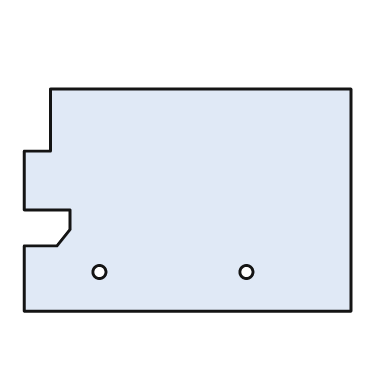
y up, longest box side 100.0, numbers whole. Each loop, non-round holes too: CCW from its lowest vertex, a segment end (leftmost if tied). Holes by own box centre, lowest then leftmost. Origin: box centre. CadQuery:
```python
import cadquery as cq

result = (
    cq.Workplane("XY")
    .moveTo(-50.0, -34.0)
    .lineTo(50.0, -34.0)
    .lineTo(50.0, 34.0)
    .lineTo(-42.0, 34.0)
    .lineTo(-42.0, 15.0)
    .lineTo(-50.0, 15.0)
    .lineTo(-50.0, -3.0)
    .lineTo(-36.0, -3.0)
    .lineTo(-36.0, -9.0)
    .lineTo(-40.0, -14.0)
    .lineTo(-50.0, -14.0)
    .close()
    .moveTo(-27.0, -22.0)
    .circle(2.0)
    .moveTo(18.0, -22.0)
    .circle(2.0)
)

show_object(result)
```